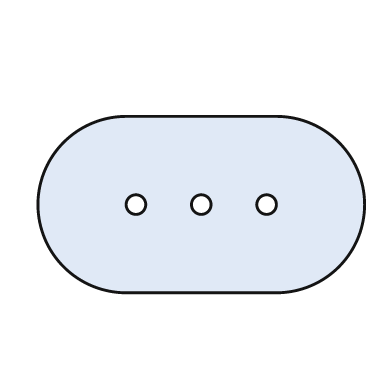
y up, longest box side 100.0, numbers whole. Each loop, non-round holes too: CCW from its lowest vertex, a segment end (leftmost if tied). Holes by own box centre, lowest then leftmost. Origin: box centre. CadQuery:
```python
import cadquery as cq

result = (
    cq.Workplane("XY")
    .moveTo(-23.0, -27.0)
    .lineTo(23.0, -27.0)
    .threePointArc((50.0, 0.0), (23.0, 27.0))
    .lineTo(-23.0, 27.0)
    .threePointArc((-50.0, 0.0), (-23.0, -27.0))
    .close()
    .moveTo(-20.0, 0.0)
    .circle(3.0)
    .moveTo(0.0, 0.0)
    .circle(3.0)
    .moveTo(20.0, 0.0)
    .circle(3.0)
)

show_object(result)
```